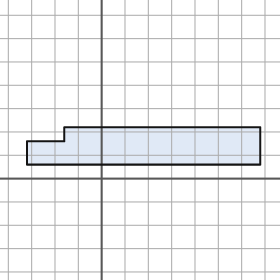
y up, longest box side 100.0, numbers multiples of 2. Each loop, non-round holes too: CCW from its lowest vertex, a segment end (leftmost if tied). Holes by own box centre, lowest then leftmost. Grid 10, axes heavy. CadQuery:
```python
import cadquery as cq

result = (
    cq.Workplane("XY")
    .moveTo(-32.0, 6.0)
    .lineTo(68.0, 6.0)
    .lineTo(68.0, 22.0)
    .lineTo(-16.0, 22.0)
    .lineTo(-16.0, 16.0)
    .lineTo(-32.0, 16.0)
    .close()
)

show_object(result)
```